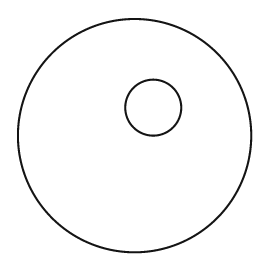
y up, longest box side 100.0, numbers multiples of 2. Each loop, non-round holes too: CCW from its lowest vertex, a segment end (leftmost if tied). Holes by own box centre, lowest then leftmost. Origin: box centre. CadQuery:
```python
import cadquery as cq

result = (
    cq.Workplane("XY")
    .moveTo(0.0, 0.0)
    .circle(50.0)
    .moveTo(8.0, 12.0)
    .circle(12.0)
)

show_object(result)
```